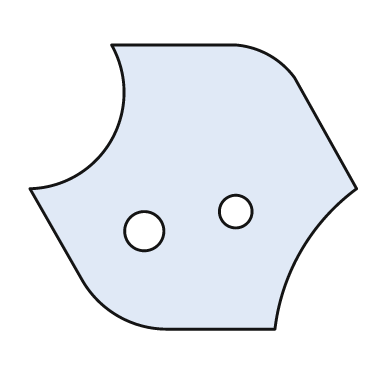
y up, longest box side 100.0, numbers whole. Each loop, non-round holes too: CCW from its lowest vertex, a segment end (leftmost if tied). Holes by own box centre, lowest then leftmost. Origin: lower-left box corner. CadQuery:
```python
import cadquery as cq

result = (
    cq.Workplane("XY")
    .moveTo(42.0, 0.0)
    .lineTo(75.0, 0.0)
    .threePointArc((83.0, 24.0), (100.0, 43.0))
    .lineTo(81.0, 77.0)
    .threePointArc((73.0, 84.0), (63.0, 87.0))
    .lineTo(25.0, 87.0)
    .threePointArc((25.0, 58.0), (0.0, 43.0))
    .lineTo(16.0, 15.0)
    .threePointArc((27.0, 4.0), (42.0, 0.0))
    .close()
    .moveTo(35.0, 30.0)
    .circle(6.0)
    .moveTo(63.0, 36.0)
    .circle(5.0)
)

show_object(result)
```